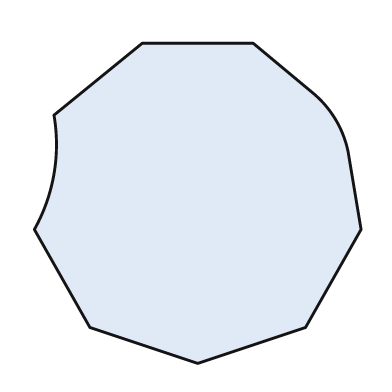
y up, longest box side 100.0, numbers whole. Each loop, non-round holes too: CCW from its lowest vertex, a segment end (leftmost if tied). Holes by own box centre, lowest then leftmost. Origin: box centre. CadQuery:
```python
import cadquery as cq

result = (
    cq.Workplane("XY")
    .moveTo(0.0, -49.0)
    .lineTo(33.0, -38.0)
    .lineTo(50.0, -8.0)
    .lineTo(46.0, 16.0)
    .threePointArc((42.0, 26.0), (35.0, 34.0))
    .lineTo(17.0, 49.0)
    .lineTo(-17.0, 49.0)
    .lineTo(-44.0, 27.0)
    .threePointArc((-44.0, 9.0), (-50.0, -8.0))
    .lineTo(-33.0, -38.0)
    .close()
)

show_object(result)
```